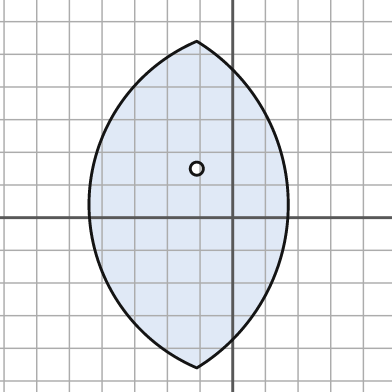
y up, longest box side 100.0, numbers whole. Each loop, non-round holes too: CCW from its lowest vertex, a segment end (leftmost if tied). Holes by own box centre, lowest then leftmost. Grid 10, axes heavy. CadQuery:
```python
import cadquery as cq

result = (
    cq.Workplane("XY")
    .moveTo(-11.0, -46.0)
    .threePointArc((17.0, 4.0), (-11.0, 54.0))
    .threePointArc((-44.0, 4.0), (-11.0, -46.0))
    .close()
    .moveTo(-11.0, 15.0)
    .circle(2.0)
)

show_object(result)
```